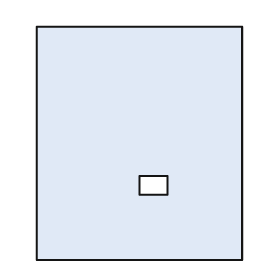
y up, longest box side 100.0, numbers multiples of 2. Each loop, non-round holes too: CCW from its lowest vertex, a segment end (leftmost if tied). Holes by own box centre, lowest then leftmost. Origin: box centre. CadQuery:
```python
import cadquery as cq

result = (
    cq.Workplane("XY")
    .moveTo(-44.0, -50.0)
    .lineTo(44.0, -50.0)
    .lineTo(44.0, 50.0)
    .lineTo(-44.0, 50.0)
    .close()
    .moveTo(0.0, -22.0)
    .lineTo(12.0, -22.0)
    .lineTo(12.0, -14.0)
    .lineTo(0.0, -14.0)
    .close()
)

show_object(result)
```